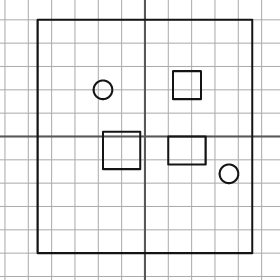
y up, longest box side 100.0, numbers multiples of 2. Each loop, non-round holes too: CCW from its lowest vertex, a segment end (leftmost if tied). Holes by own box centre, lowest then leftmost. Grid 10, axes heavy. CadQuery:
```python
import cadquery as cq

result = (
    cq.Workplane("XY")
    .moveTo(-46.0, -50.0)
    .lineTo(46.0, -50.0)
    .lineTo(46.0, 50.0)
    .lineTo(-46.0, 50.0)
    .close()
    .moveTo(36.0, -16.0)
    .circle(4.0)
    .moveTo(-18.0, -14.0)
    .lineTo(-2.0, -14.0)
    .lineTo(-2.0, 2.0)
    .lineTo(-18.0, 2.0)
    .close()
    .moveTo(10.0, -12.0)
    .lineTo(26.0, -12.0)
    .lineTo(26.0, 0.0)
    .lineTo(10.0, 0.0)
    .close()
    .moveTo(-18.0, 20.0)
    .circle(4.0)
    .moveTo(12.0, 16.0)
    .lineTo(24.0, 16.0)
    .lineTo(24.0, 28.0)
    .lineTo(12.0, 28.0)
    .close()
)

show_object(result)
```